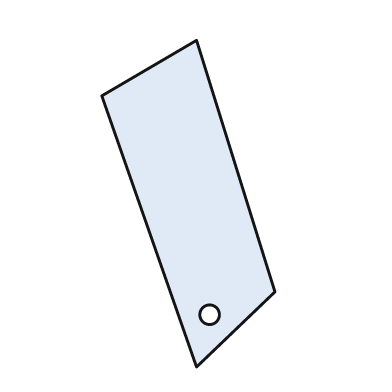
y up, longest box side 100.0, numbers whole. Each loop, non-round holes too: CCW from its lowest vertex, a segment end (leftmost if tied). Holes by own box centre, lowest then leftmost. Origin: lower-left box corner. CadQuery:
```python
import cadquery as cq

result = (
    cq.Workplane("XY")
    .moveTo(29.0, 0.0)
    .lineTo(53.0, 23.0)
    .lineTo(29.0, 100.0)
    .lineTo(0.0, 83.0)
    .close()
    .moveTo(33.0, 16.0)
    .circle(3.0)
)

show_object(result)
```